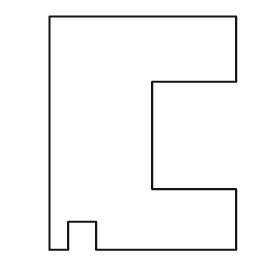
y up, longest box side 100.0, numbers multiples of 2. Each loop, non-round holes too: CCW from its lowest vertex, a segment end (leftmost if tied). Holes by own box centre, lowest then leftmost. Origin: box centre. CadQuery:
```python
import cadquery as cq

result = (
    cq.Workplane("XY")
    .moveTo(-40.0, -50.0)
    .lineTo(-32.0, -50.0)
    .lineTo(-32.0, -38.0)
    .lineTo(-20.0, -38.0)
    .lineTo(-20.0, -50.0)
    .lineTo(40.0, -50.0)
    .lineTo(40.0, -24.0)
    .lineTo(4.0, -24.0)
    .lineTo(4.0, 22.0)
    .lineTo(40.0, 22.0)
    .lineTo(40.0, 50.0)
    .lineTo(-40.0, 50.0)
    .close()
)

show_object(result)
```